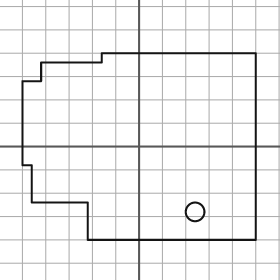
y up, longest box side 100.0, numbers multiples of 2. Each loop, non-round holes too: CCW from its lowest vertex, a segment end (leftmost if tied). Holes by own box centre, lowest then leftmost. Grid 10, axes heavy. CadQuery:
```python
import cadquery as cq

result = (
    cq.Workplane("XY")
    .moveTo(-22.0, -40.0)
    .lineTo(50.0, -40.0)
    .lineTo(50.0, 40.0)
    .lineTo(-16.0, 40.0)
    .lineTo(-16.0, 36.0)
    .lineTo(-42.0, 36.0)
    .lineTo(-42.0, 28.0)
    .lineTo(-50.0, 28.0)
    .lineTo(-50.0, -8.0)
    .lineTo(-46.0, -8.0)
    .lineTo(-46.0, -24.0)
    .lineTo(-22.0, -24.0)
    .close()
    .moveTo(24.0, -28.0)
    .circle(4.0)
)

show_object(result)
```